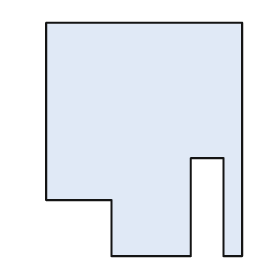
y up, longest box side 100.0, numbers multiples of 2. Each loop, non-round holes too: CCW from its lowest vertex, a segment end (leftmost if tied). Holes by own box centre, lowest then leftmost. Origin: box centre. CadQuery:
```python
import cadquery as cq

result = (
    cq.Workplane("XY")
    .moveTo(-14.0, -50.0)
    .lineTo(20.0, -50.0)
    .lineTo(20.0, -8.0)
    .lineTo(34.0, -8.0)
    .lineTo(34.0, -50.0)
    .lineTo(42.0, -50.0)
    .lineTo(42.0, 50.0)
    .lineTo(-42.0, 50.0)
    .lineTo(-42.0, -26.0)
    .lineTo(-14.0, -26.0)
    .close()
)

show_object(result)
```